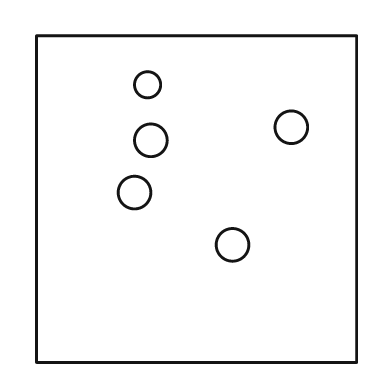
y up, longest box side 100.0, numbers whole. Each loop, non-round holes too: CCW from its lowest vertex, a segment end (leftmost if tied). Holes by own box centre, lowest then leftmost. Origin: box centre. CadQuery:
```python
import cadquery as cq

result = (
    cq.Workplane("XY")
    .moveTo(-49.0, -50.0)
    .lineTo(49.0, -50.0)
    .lineTo(49.0, 50.0)
    .lineTo(-49.0, 50.0)
    .close()
    .moveTo(11.0, -14.0)
    .circle(5.0)
    .moveTo(-19.0, 2.0)
    .circle(5.0)
    .moveTo(-14.0, 18.0)
    .circle(5.0)
    .moveTo(29.0, 22.0)
    .circle(5.0)
    .moveTo(-15.0, 35.0)
    .circle(4.0)
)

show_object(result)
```